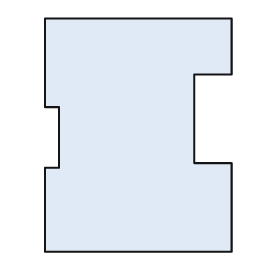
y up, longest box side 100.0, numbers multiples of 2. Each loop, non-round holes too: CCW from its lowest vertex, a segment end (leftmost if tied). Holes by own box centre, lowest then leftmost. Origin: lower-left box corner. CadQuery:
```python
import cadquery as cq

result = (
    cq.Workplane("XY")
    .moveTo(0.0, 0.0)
    .lineTo(80.0, 0.0)
    .lineTo(80.0, 38.0)
    .lineTo(64.0, 38.0)
    .lineTo(64.0, 76.0)
    .lineTo(80.0, 76.0)
    .lineTo(80.0, 100.0)
    .lineTo(0.0, 100.0)
    .lineTo(0.0, 62.0)
    .lineTo(6.0, 62.0)
    .lineTo(6.0, 36.0)
    .lineTo(0.0, 36.0)
    .close()
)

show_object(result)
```